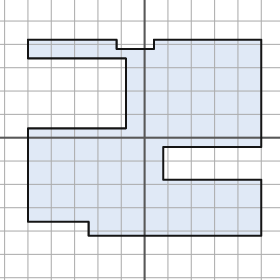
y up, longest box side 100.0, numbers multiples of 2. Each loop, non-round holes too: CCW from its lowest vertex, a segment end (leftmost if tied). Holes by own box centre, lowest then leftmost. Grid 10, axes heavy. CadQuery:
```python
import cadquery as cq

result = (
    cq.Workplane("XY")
    .moveTo(-24.0, -42.0)
    .lineTo(50.0, -42.0)
    .lineTo(50.0, -18.0)
    .lineTo(8.0, -18.0)
    .lineTo(8.0, -4.0)
    .lineTo(50.0, -4.0)
    .lineTo(50.0, 42.0)
    .lineTo(4.0, 42.0)
    .lineTo(4.0, 38.0)
    .lineTo(-12.0, 38.0)
    .lineTo(-12.0, 42.0)
    .lineTo(-50.0, 42.0)
    .lineTo(-50.0, 34.0)
    .lineTo(-8.0, 34.0)
    .lineTo(-8.0, 4.0)
    .lineTo(-50.0, 4.0)
    .lineTo(-50.0, -36.0)
    .lineTo(-24.0, -36.0)
    .close()
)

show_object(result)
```